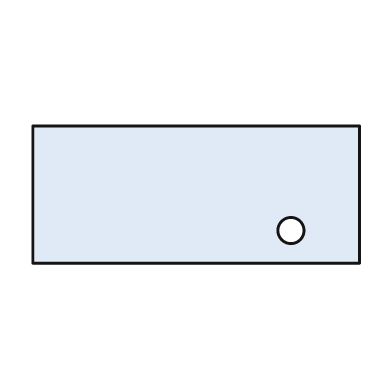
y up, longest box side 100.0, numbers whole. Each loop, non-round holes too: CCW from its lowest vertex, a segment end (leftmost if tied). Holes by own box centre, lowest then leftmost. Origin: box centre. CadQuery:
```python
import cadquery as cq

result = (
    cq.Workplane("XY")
    .moveTo(-50.0, -21.0)
    .lineTo(50.0, -21.0)
    .lineTo(50.0, 21.0)
    .lineTo(-50.0, 21.0)
    .close()
    .moveTo(29.0, -11.0)
    .circle(4.0)
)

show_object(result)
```